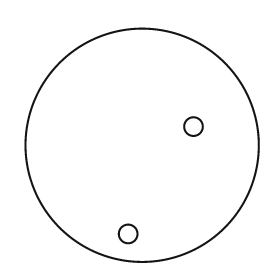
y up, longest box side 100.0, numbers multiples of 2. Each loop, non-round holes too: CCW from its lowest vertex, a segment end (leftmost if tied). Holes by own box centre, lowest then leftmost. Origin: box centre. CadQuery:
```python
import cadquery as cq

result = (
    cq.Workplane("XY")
    .moveTo(0.0, 0.0)
    .circle(50.0)
    .moveTo(-6.0, -38.0)
    .circle(4.0)
    .moveTo(22.0, 8.0)
    .circle(4.0)
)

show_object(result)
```